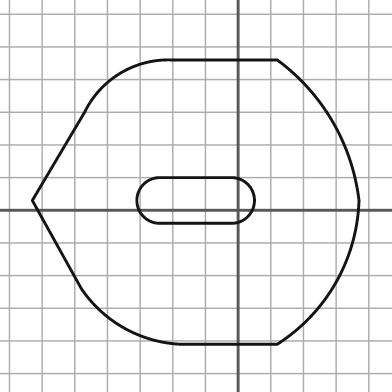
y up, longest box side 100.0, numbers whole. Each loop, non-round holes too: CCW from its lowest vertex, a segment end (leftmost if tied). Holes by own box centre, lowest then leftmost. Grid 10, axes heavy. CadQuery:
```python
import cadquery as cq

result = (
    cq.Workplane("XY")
    .moveTo(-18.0, -41.0)
    .lineTo(12.0, -41.0)
    .threePointArc((30.0, -22.0), (37.0, 3.0))
    .threePointArc((29.0, 27.0), (12.0, 46.0))
    .lineTo(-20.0, 46.0)
    .threePointArc((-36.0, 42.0), (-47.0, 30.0))
    .lineTo(-63.0, 3.0)
    .lineTo(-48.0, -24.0)
    .threePointArc((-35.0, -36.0), (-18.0, -41.0))
    .close()
    .moveTo(-24.0, -4.0)
    .lineTo(-2.0, -4.0)
    .threePointArc((5.0, 3.0), (-2.0, 10.0))
    .lineTo(-24.0, 10.0)
    .threePointArc((-31.0, 3.0), (-24.0, -4.0))
    .close()
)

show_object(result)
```